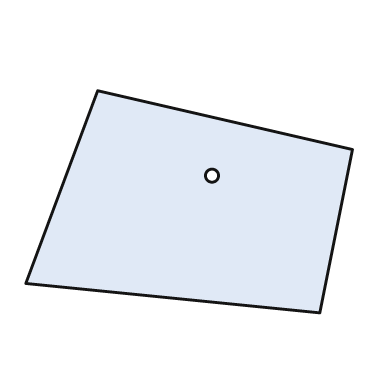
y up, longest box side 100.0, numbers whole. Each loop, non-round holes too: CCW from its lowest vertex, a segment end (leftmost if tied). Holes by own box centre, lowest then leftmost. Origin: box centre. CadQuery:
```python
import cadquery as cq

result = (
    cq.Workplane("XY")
    .moveTo(40.0, -34.0)
    .lineTo(50.0, 16.0)
    .lineTo(-28.0, 34.0)
    .lineTo(-50.0, -25.0)
    .close()
    .moveTo(7.0, 8.0)
    .circle(2.0)
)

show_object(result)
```